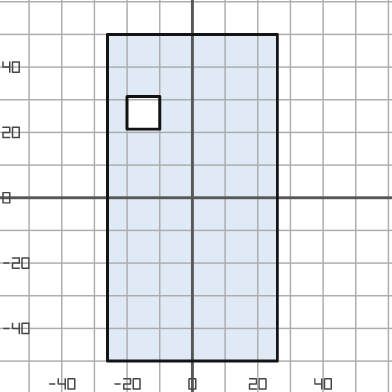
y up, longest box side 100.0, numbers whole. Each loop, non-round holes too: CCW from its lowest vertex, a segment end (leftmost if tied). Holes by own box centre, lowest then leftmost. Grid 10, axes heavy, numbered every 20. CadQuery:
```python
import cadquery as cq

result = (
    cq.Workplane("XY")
    .moveTo(-26.0, -50.0)
    .lineTo(26.0, -50.0)
    .lineTo(26.0, 50.0)
    .lineTo(-26.0, 50.0)
    .close()
    .moveTo(-20.0, 21.0)
    .lineTo(-10.0, 21.0)
    .lineTo(-10.0, 31.0)
    .lineTo(-20.0, 31.0)
    .close()
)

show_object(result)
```